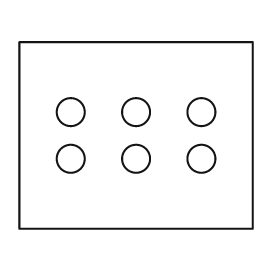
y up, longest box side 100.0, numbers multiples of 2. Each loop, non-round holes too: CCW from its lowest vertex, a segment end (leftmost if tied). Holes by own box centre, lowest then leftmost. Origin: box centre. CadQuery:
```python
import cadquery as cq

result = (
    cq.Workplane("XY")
    .moveTo(-50.0, -40.0)
    .lineTo(50.0, -40.0)
    .lineTo(50.0, 40.0)
    .lineTo(-50.0, 40.0)
    .close()
    .moveTo(-28.0, -10.0)
    .circle(6.0)
    .moveTo(0.0, -10.0)
    .circle(6.0)
    .moveTo(28.0, -10.0)
    .circle(6.0)
    .moveTo(-28.0, 10.0)
    .circle(6.0)
    .moveTo(0.0, 10.0)
    .circle(6.0)
    .moveTo(28.0, 10.0)
    .circle(6.0)
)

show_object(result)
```